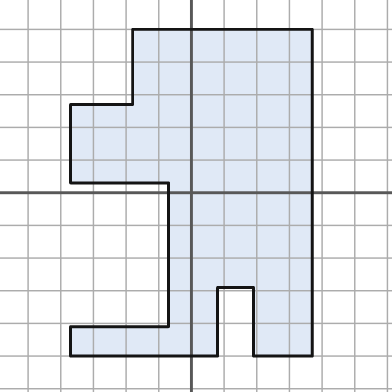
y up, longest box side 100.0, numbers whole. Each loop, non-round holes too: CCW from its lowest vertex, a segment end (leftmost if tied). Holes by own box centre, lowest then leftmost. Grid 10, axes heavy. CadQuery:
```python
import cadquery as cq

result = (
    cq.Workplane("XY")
    .moveTo(-37.0, -50.0)
    .lineTo(8.0, -50.0)
    .lineTo(8.0, -29.0)
    .lineTo(19.0, -29.0)
    .lineTo(19.0, -50.0)
    .lineTo(37.0, -50.0)
    .lineTo(37.0, 50.0)
    .lineTo(-18.0, 50.0)
    .lineTo(-18.0, 27.0)
    .lineTo(-37.0, 27.0)
    .lineTo(-37.0, 3.0)
    .lineTo(-7.0, 3.0)
    .lineTo(-7.0, -41.0)
    .lineTo(-37.0, -41.0)
    .close()
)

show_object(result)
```